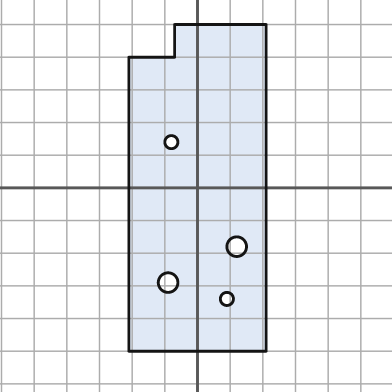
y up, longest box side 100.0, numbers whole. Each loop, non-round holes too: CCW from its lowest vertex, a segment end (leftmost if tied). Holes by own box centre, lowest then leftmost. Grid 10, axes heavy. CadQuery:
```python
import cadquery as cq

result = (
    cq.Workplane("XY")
    .moveTo(-21.0, -50.0)
    .lineTo(21.0, -50.0)
    .lineTo(21.0, 50.0)
    .lineTo(-7.0, 50.0)
    .lineTo(-7.0, 40.0)
    .lineTo(-21.0, 40.0)
    .close()
    .moveTo(9.0, -34.0)
    .circle(2.0)
    .moveTo(-9.0, -29.0)
    .circle(3.0)
    .moveTo(12.0, -18.0)
    .circle(3.0)
    .moveTo(-8.0, 14.0)
    .circle(2.0)
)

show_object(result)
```